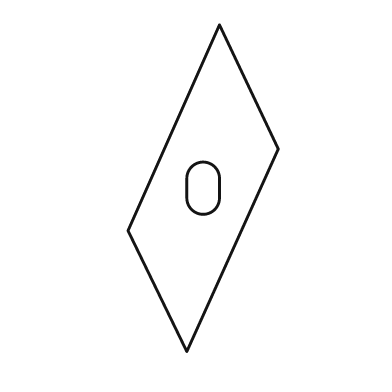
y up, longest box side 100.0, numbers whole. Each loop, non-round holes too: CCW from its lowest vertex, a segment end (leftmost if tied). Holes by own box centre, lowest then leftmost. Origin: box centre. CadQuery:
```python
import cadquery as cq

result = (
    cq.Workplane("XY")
    .moveTo(-5.0, -50.0)
    .lineTo(23.0, 12.0)
    .lineTo(5.0, 50.0)
    .lineTo(-23.0, -13.0)
    .close()
    .moveTo(-5.0, -3.0)
    .threePointArc((0.0, -8.0), (5.0, -3.0))
    .lineTo(5.0, 3.0)
    .threePointArc((0.0, 8.0), (-5.0, 3.0))
    .close()
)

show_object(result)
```